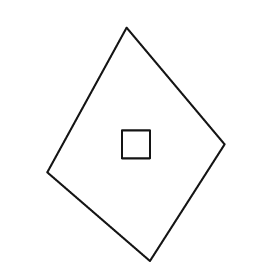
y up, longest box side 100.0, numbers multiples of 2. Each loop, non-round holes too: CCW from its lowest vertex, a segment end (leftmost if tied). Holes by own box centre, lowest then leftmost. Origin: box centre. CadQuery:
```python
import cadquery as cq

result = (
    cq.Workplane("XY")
    .moveTo(6.0, -50.0)
    .lineTo(38.0, 0.0)
    .lineTo(-4.0, 50.0)
    .lineTo(-38.0, -12.0)
    .close()
    .moveTo(-6.0, -6.0)
    .lineTo(6.0, -6.0)
    .lineTo(6.0, 6.0)
    .lineTo(-6.0, 6.0)
    .close()
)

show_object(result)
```